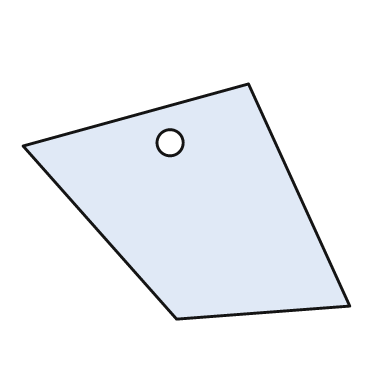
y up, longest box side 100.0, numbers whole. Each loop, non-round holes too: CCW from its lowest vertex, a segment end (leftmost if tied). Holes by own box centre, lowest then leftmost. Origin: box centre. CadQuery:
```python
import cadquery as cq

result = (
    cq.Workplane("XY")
    .moveTo(-3.0, -36.0)
    .lineTo(50.0, -32.0)
    .lineTo(19.0, 36.0)
    .lineTo(-50.0, 17.0)
    .close()
    .moveTo(-5.0, 18.0)
    .circle(4.0)
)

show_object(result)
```